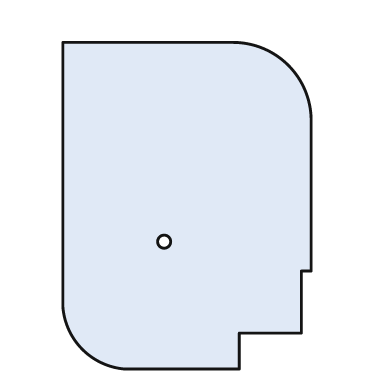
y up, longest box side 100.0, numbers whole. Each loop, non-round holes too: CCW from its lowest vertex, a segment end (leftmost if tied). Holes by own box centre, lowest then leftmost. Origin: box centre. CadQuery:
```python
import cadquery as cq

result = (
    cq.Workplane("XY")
    .moveTo(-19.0, -50.0)
    .lineTo(16.0, -50.0)
    .lineTo(16.0, -39.0)
    .lineTo(35.0, -39.0)
    .lineTo(35.0, -20.0)
    .lineTo(38.0, -20.0)
    .lineTo(38.0, 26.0)
    .threePointArc((31.0, 43.0), (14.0, 50.0))
    .lineTo(-38.0, 50.0)
    .lineTo(-38.0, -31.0)
    .threePointArc((-32.0, -44.0), (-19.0, -50.0))
    .close()
    .moveTo(-7.0, -11.0)
    .circle(2.0)
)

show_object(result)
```